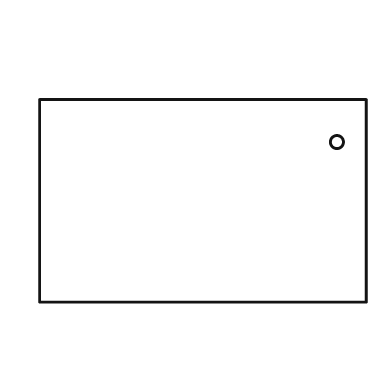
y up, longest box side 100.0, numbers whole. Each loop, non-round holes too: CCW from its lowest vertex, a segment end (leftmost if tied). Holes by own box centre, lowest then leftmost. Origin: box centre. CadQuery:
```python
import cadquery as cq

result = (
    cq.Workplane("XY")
    .moveTo(-50.0, -31.0)
    .lineTo(50.0, -31.0)
    .lineTo(50.0, 31.0)
    .lineTo(-50.0, 31.0)
    .close()
    .moveTo(41.0, 18.0)
    .circle(2.0)
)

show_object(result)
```